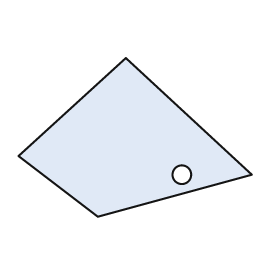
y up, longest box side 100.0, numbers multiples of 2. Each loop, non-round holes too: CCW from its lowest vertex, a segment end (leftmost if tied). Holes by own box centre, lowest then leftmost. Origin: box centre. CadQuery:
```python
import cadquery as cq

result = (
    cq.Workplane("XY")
    .moveTo(-16.0, -34.0)
    .lineTo(50.0, -16.0)
    .lineTo(-4.0, 34.0)
    .lineTo(-50.0, -8.0)
    .close()
    .moveTo(20.0, -16.0)
    .circle(4.0)
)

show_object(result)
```